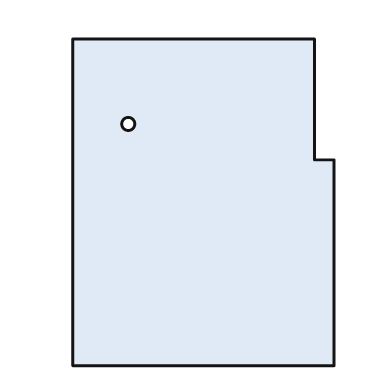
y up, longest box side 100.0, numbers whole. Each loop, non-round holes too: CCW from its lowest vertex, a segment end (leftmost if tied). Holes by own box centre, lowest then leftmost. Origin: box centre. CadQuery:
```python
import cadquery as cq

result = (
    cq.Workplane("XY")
    .moveTo(-40.0, -50.0)
    .lineTo(40.0, -50.0)
    .lineTo(40.0, 13.0)
    .lineTo(34.0, 13.0)
    .lineTo(34.0, 50.0)
    .lineTo(-40.0, 50.0)
    .close()
    .moveTo(-23.0, 24.0)
    .circle(2.0)
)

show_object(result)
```